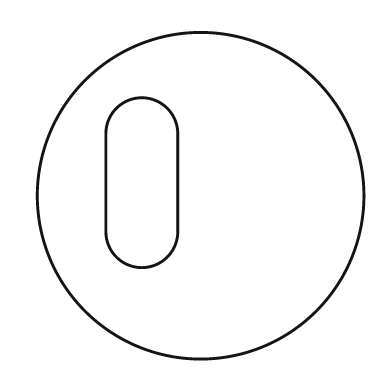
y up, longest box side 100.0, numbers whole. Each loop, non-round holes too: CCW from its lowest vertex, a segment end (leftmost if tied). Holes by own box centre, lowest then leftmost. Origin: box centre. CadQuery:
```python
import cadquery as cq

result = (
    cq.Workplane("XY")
    .moveTo(0.0, 0.0)
    .circle(50.0)
    .moveTo(-29.0, -11.0)
    .threePointArc((-18.0, -22.0), (-7.0, -11.0))
    .lineTo(-7.0, 19.0)
    .threePointArc((-18.0, 30.0), (-29.0, 19.0))
    .close()
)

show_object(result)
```